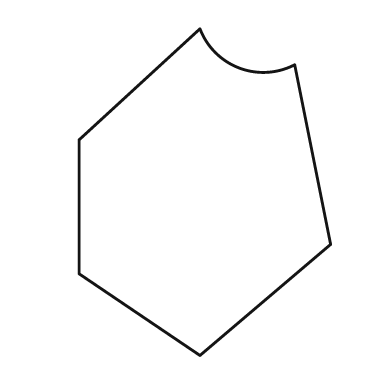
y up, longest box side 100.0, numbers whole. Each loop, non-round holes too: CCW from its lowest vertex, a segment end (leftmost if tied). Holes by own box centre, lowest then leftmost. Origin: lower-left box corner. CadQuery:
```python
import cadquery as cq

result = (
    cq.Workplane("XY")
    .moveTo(37.0, 0.0)
    .lineTo(77.0, 34.0)
    .lineTo(66.0, 89.0)
    .threePointArc((49.0, 88.0), (37.0, 100.0))
    .lineTo(0.0, 66.0)
    .lineTo(0.0, 25.0)
    .close()
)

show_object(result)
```